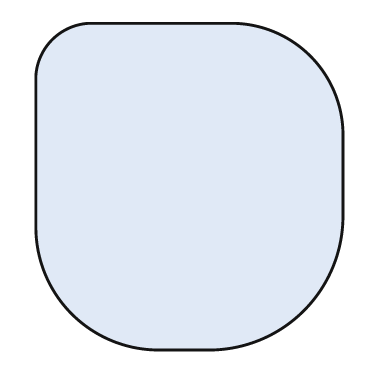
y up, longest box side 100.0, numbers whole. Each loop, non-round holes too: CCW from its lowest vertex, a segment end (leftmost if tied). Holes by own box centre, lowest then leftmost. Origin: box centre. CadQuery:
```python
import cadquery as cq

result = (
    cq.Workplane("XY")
    .moveTo(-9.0, -50.0)
    .lineTo(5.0, -50.0)
    .threePointArc((35.0, -38.0), (47.0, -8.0))
    .lineTo(47.0, 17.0)
    .threePointArc((37.0, 40.0), (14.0, 50.0))
    .lineTo(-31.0, 50.0)
    .threePointArc((-42.0, 45.0), (-47.0, 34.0))
    .lineTo(-47.0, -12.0)
    .threePointArc((-36.0, -39.0), (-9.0, -50.0))
    .close()
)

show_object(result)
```